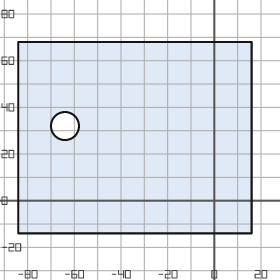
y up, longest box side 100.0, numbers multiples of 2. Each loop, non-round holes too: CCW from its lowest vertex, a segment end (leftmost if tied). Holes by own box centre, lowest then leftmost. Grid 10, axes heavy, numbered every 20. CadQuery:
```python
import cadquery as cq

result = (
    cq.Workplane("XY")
    .moveTo(-84.0, -14.0)
    .lineTo(16.0, -14.0)
    .lineTo(16.0, 68.0)
    .lineTo(-84.0, 68.0)
    .close()
    .moveTo(-64.0, 32.0)
    .circle(6.0)
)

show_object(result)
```